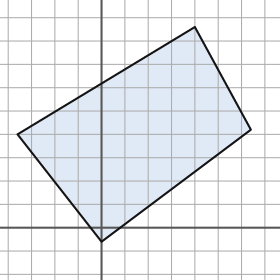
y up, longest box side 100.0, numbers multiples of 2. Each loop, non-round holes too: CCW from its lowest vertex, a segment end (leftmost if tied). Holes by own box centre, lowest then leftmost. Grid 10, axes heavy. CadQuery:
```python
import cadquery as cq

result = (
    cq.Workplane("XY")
    .moveTo(0.0, -6.0)
    .lineTo(64.0, 42.0)
    .lineTo(40.0, 86.0)
    .lineTo(-36.0, 40.0)
    .close()
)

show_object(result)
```